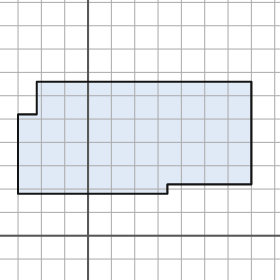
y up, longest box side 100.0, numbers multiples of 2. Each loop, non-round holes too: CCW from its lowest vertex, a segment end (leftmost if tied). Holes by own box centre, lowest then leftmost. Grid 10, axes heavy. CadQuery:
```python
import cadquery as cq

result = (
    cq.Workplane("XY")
    .moveTo(-30.0, 18.0)
    .lineTo(34.0, 18.0)
    .lineTo(34.0, 22.0)
    .lineTo(70.0, 22.0)
    .lineTo(70.0, 66.0)
    .lineTo(-22.0, 66.0)
    .lineTo(-22.0, 52.0)
    .lineTo(-30.0, 52.0)
    .close()
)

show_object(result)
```